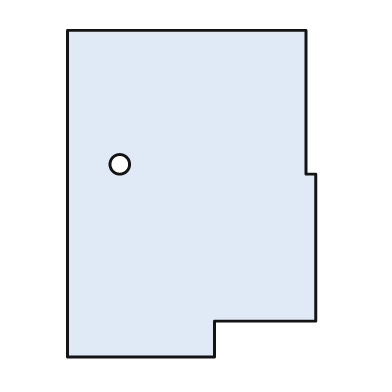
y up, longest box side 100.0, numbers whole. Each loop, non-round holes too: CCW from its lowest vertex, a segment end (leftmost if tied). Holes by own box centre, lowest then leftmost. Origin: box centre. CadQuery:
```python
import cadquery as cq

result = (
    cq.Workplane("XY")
    .moveTo(-38.0, -50.0)
    .lineTo(7.0, -50.0)
    .lineTo(7.0, -39.0)
    .lineTo(38.0, -39.0)
    .lineTo(38.0, 6.0)
    .lineTo(35.0, 6.0)
    .lineTo(35.0, 50.0)
    .lineTo(-38.0, 50.0)
    .close()
    .moveTo(-22.0, 9.0)
    .circle(3.0)
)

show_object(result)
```